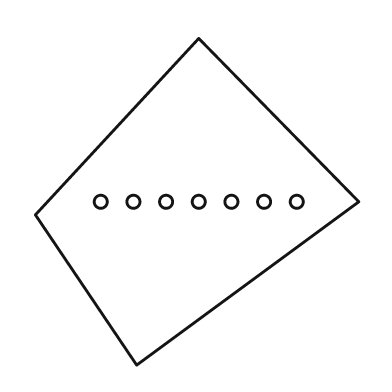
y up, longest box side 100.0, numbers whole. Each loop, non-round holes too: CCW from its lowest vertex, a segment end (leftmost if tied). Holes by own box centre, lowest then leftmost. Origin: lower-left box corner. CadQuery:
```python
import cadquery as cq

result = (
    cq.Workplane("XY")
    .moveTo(31.0, 0.0)
    .lineTo(99.0, 50.0)
    .lineTo(50.0, 100.0)
    .lineTo(0.0, 46.0)
    .close()
    .moveTo(20.0, 50.0)
    .circle(2.0)
    .moveTo(30.0, 50.0)
    .circle(2.0)
    .moveTo(40.0, 50.0)
    .circle(2.0)
    .moveTo(50.0, 50.0)
    .circle(2.0)
    .moveTo(60.0, 50.0)
    .circle(2.0)
    .moveTo(70.0, 50.0)
    .circle(2.0)
    .moveTo(80.0, 50.0)
    .circle(2.0)
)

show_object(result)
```